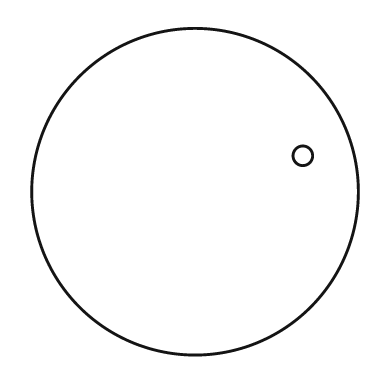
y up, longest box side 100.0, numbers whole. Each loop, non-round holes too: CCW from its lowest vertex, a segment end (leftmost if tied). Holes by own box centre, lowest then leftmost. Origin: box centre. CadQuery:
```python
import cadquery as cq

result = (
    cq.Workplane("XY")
    .moveTo(0.0, 0.0)
    .circle(50.0)
    .moveTo(33.0, 11.0)
    .circle(3.0)
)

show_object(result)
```